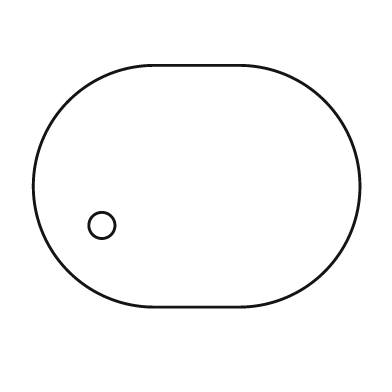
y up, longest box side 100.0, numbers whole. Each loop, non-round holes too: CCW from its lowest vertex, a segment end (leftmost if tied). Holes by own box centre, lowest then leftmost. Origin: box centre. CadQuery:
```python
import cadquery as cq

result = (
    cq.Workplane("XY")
    .moveTo(-13.0, -37.0)
    .lineTo(13.0, -37.0)
    .threePointArc((50.0, 0.0), (13.0, 37.0))
    .lineTo(-13.0, 37.0)
    .threePointArc((-50.0, 0.0), (-13.0, -37.0))
    .close()
    .moveTo(-29.0, -12.0)
    .circle(4.0)
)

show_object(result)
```